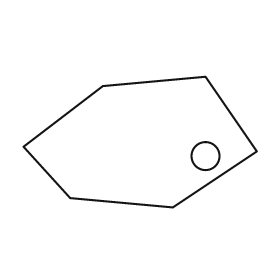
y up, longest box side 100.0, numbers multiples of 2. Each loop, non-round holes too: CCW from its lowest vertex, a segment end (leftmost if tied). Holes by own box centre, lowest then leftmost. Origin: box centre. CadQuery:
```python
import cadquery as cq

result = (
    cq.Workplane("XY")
    .moveTo(14.0, -28.0)
    .lineTo(50.0, -4.0)
    .lineTo(28.0, 28.0)
    .lineTo(-16.0, 24.0)
    .lineTo(-50.0, -2.0)
    .lineTo(-30.0, -24.0)
    .close()
    .moveTo(28.0, -6.0)
    .circle(6.0)
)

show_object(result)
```